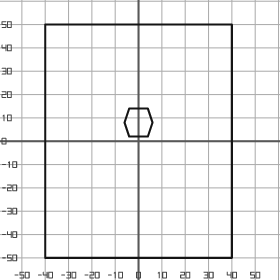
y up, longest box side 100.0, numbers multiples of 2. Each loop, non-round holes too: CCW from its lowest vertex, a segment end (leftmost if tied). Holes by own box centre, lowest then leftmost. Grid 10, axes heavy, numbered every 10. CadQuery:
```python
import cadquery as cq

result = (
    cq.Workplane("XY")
    .moveTo(-40.0, -50.0)
    .lineTo(40.0, -50.0)
    .lineTo(40.0, 50.0)
    .lineTo(-40.0, 50.0)
    .close()
    .moveTo(-4.0, 2.0)
    .lineTo(4.0, 2.0)
    .lineTo(6.0, 8.0)
    .lineTo(4.0, 14.0)
    .lineTo(-4.0, 14.0)
    .lineTo(-6.0, 8.0)
    .close()
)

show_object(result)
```